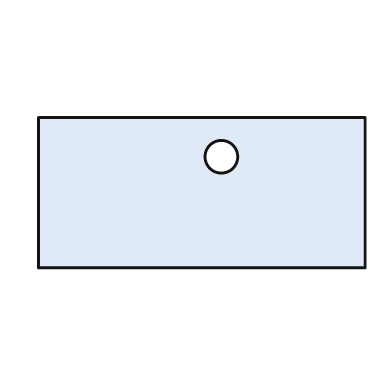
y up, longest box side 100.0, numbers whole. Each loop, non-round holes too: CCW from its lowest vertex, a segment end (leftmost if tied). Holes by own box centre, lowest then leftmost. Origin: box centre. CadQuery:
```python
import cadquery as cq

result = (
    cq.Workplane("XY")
    .moveTo(-50.0, -23.0)
    .lineTo(50.0, -23.0)
    .lineTo(50.0, 23.0)
    .lineTo(-50.0, 23.0)
    .close()
    .moveTo(6.0, 11.0)
    .circle(5.0)
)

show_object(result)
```